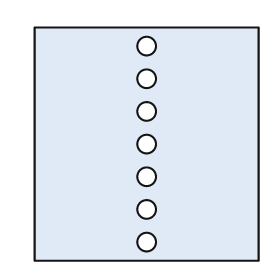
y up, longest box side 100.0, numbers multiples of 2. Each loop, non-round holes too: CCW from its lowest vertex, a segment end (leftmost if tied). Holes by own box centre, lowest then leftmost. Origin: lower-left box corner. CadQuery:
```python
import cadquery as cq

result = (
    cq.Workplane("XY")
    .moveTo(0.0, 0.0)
    .lineTo(96.0, 0.0)
    .lineTo(96.0, 100.0)
    .lineTo(0.0, 100.0)
    .close()
    .moveTo(48.0, 8.0)
    .circle(4.0)
    .moveTo(48.0, 22.0)
    .circle(4.0)
    .moveTo(48.0, 36.0)
    .circle(4.0)
    .moveTo(48.0, 50.0)
    .circle(4.0)
    .moveTo(48.0, 64.0)
    .circle(4.0)
    .moveTo(48.0, 78.0)
    .circle(4.0)
    .moveTo(48.0, 92.0)
    .circle(4.0)
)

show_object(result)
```